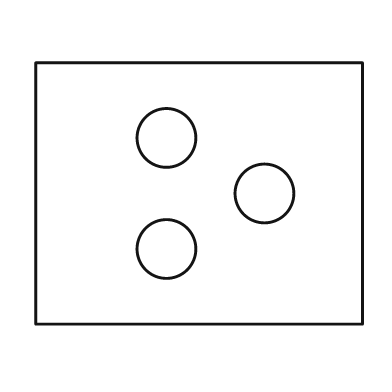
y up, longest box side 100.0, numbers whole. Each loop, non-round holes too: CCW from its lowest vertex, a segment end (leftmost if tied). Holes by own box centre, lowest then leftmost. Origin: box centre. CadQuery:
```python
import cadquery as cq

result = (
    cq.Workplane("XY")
    .moveTo(-50.0, -40.0)
    .lineTo(50.0, -40.0)
    .lineTo(50.0, 40.0)
    .lineTo(-50.0, 40.0)
    .close()
    .moveTo(-10.0, -17.0)
    .circle(9.0)
    .moveTo(20.0, 0.0)
    .circle(9.0)
    .moveTo(-10.0, 17.0)
    .circle(9.0)
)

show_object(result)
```